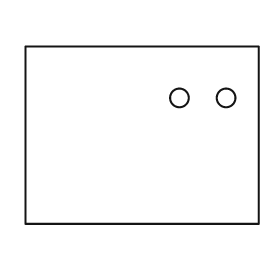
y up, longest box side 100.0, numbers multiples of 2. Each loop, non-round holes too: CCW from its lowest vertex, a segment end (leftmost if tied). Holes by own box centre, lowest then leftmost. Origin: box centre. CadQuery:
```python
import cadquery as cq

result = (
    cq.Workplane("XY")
    .moveTo(-50.0, -38.0)
    .lineTo(50.0, -38.0)
    .lineTo(50.0, 38.0)
    .lineTo(-50.0, 38.0)
    .close()
    .moveTo(16.0, 16.0)
    .circle(4.0)
    .moveTo(36.0, 16.0)
    .circle(4.0)
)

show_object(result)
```